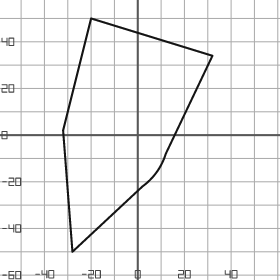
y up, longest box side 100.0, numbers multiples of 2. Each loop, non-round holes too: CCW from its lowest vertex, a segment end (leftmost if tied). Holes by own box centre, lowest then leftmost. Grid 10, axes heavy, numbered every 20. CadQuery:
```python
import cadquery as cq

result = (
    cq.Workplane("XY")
    .moveTo(-28.0, -50.0)
    .lineTo(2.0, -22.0)
    .threePointArc((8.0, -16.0), (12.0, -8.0))
    .lineTo(32.0, 34.0)
    .lineTo(-20.0, 50.0)
    .lineTo(-32.0, 2.0)
    .close()
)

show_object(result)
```